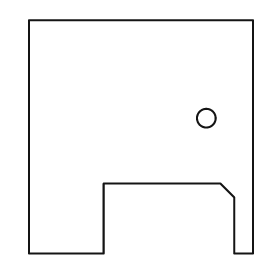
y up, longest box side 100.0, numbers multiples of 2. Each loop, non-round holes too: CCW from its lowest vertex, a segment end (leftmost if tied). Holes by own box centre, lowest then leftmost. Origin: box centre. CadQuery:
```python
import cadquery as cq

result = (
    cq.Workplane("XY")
    .moveTo(-48.0, -50.0)
    .lineTo(-16.0, -50.0)
    .lineTo(-16.0, -20.0)
    .lineTo(34.0, -20.0)
    .lineTo(40.0, -26.0)
    .lineTo(40.0, -50.0)
    .lineTo(48.0, -50.0)
    .lineTo(48.0, 50.0)
    .lineTo(-48.0, 50.0)
    .close()
    .moveTo(28.0, 8.0)
    .circle(4.0)
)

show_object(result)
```